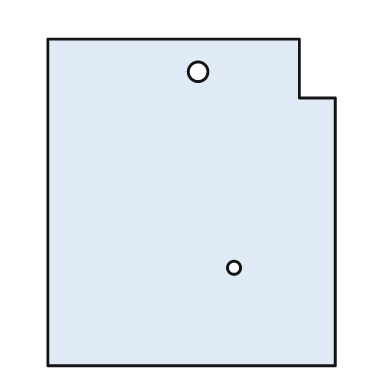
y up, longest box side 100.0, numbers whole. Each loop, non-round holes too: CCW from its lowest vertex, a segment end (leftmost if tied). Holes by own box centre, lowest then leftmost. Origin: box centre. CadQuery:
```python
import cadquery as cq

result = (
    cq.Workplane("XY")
    .moveTo(-44.0, -50.0)
    .lineTo(44.0, -50.0)
    .lineTo(44.0, 32.0)
    .lineTo(33.0, 32.0)
    .lineTo(33.0, 50.0)
    .lineTo(-44.0, 50.0)
    .close()
    .moveTo(13.0, -20.0)
    .circle(2.0)
    .moveTo(2.0, 40.0)
    .circle(3.0)
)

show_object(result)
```